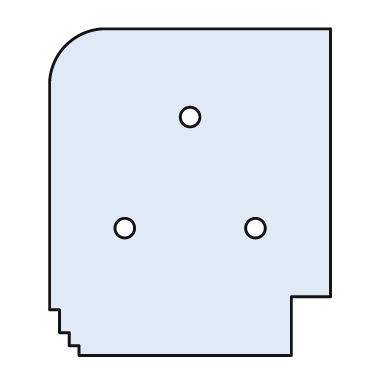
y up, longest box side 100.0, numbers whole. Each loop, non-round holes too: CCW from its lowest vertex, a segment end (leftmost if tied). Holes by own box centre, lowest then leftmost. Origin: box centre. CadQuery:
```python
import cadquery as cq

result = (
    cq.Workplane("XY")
    .moveTo(-34.0, -50.0)
    .lineTo(31.0, -50.0)
    .lineTo(31.0, -32.0)
    .lineTo(43.0, -32.0)
    .lineTo(43.0, 50.0)
    .lineTo(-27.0, 50.0)
    .threePointArc((-38.0, 45.0), (-43.0, 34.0))
    .lineTo(-43.0, -36.0)
    .lineTo(-40.0, -36.0)
    .lineTo(-40.0, -43.0)
    .lineTo(-37.0, -43.0)
    .lineTo(-37.0, -47.0)
    .lineTo(-34.0, -47.0)
    .close()
    .moveTo(-20.0, -11.0)
    .circle(3.0)
    .moveTo(20.0, -11.0)
    .circle(3.0)
    .moveTo(0.0, 23.0)
    .circle(3.0)
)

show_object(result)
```